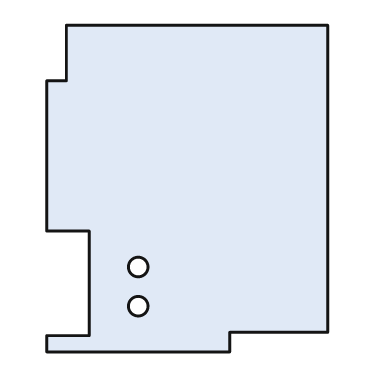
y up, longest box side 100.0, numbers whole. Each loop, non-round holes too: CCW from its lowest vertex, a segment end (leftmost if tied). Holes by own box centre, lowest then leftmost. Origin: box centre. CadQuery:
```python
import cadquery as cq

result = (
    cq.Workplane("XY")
    .moveTo(-43.0, -50.0)
    .lineTo(13.0, -50.0)
    .lineTo(13.0, -44.0)
    .lineTo(43.0, -44.0)
    .lineTo(43.0, 50.0)
    .lineTo(-37.0, 50.0)
    .lineTo(-37.0, 33.0)
    .lineTo(-43.0, 33.0)
    .lineTo(-43.0, -13.0)
    .lineTo(-30.0, -13.0)
    .lineTo(-30.0, -45.0)
    .lineTo(-43.0, -45.0)
    .close()
    .moveTo(-15.0, -36.0)
    .circle(3.0)
    .moveTo(-15.0, -24.0)
    .circle(3.0)
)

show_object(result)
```